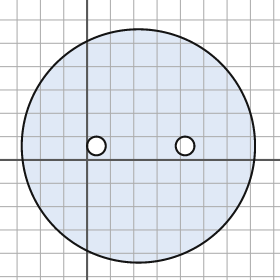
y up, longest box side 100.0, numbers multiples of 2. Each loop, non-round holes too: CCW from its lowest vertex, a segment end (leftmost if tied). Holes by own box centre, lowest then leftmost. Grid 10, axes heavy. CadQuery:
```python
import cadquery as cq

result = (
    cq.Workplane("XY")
    .moveTo(22.0, 6.0)
    .circle(50.0)
    .moveTo(4.0, 6.0)
    .circle(4.0)
    .moveTo(42.0, 6.0)
    .circle(4.0)
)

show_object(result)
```